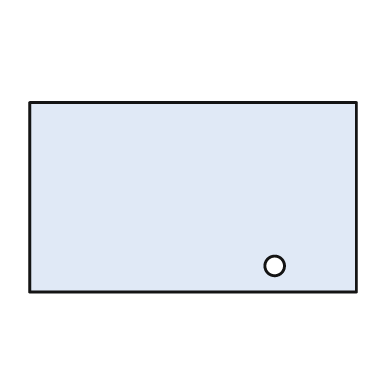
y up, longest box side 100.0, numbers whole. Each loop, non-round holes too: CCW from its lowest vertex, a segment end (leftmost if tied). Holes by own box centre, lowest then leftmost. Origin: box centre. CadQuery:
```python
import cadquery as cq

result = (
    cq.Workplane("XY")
    .moveTo(-50.0, -29.0)
    .lineTo(50.0, -29.0)
    .lineTo(50.0, 29.0)
    .lineTo(-50.0, 29.0)
    .close()
    .moveTo(25.0, -21.0)
    .circle(3.0)
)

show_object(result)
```